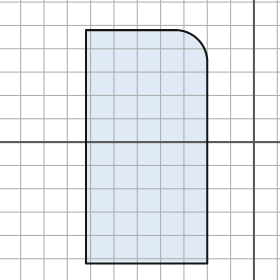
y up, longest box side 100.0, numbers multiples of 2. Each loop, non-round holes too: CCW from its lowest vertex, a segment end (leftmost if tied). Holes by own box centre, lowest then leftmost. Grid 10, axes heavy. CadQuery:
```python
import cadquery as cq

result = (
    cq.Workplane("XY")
    .moveTo(-72.0, -52.0)
    .lineTo(-20.0, -52.0)
    .lineTo(-20.0, 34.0)
    .threePointArc((-24.0, 44.0), (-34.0, 48.0))
    .lineTo(-72.0, 48.0)
    .close()
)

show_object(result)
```